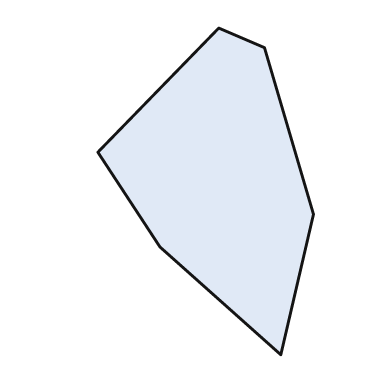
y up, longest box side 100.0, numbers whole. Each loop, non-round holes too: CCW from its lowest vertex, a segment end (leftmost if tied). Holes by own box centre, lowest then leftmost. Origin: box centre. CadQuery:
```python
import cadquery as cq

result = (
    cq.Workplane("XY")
    .moveTo(23.0, -50.0)
    .lineTo(33.0, -7.0)
    .lineTo(18.0, 44.0)
    .lineTo(4.0, 50.0)
    .lineTo(-33.0, 12.0)
    .lineTo(-14.0, -17.0)
    .close()
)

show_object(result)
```